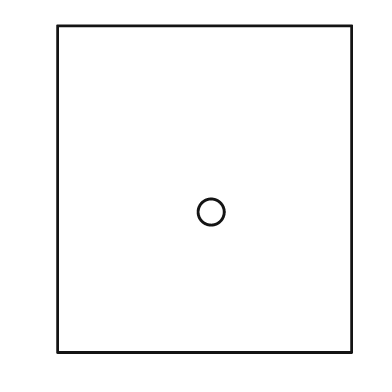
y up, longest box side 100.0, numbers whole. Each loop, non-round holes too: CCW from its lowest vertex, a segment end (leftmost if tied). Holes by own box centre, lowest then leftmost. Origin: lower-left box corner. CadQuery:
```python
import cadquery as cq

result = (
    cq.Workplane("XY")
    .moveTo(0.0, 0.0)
    .lineTo(90.0, 0.0)
    .lineTo(90.0, 100.0)
    .lineTo(0.0, 100.0)
    .close()
    .moveTo(47.0, 43.0)
    .circle(4.0)
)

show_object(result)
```